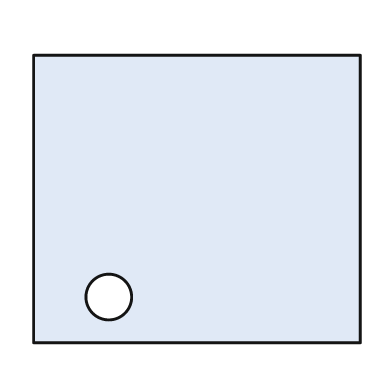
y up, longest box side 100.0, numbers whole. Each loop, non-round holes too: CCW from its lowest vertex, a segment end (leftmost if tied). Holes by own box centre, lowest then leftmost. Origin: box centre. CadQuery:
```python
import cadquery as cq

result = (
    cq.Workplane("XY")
    .moveTo(-50.0, -44.0)
    .lineTo(50.0, -44.0)
    .lineTo(50.0, 44.0)
    .lineTo(-50.0, 44.0)
    .close()
    .moveTo(-27.0, -30.0)
    .circle(7.0)
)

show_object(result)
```